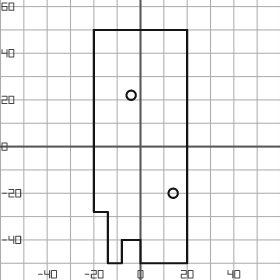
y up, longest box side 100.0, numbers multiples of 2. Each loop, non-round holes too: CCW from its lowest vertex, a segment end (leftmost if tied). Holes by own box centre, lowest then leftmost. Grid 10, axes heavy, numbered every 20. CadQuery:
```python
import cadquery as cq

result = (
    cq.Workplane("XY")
    .moveTo(-14.0, -50.0)
    .lineTo(-8.0, -50.0)
    .lineTo(-8.0, -40.0)
    .lineTo(0.0, -40.0)
    .lineTo(0.0, -50.0)
    .lineTo(20.0, -50.0)
    .lineTo(20.0, 50.0)
    .lineTo(-20.0, 50.0)
    .lineTo(-20.0, -28.0)
    .lineTo(-14.0, -28.0)
    .close()
    .moveTo(14.0, -20.0)
    .circle(2.0)
    .moveTo(-4.0, 22.0)
    .circle(2.0)
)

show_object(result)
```